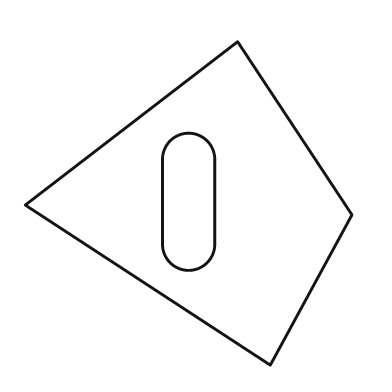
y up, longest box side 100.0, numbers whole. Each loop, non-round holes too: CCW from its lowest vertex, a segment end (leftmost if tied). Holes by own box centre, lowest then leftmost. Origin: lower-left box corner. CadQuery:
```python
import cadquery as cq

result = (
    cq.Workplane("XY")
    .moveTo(75.0, 0.0)
    .lineTo(100.0, 46.0)
    .lineTo(65.0, 99.0)
    .lineTo(0.0, 49.0)
    .close()
    .moveTo(42.0, 37.0)
    .threePointArc((50.0, 29.0), (58.0, 37.0))
    .lineTo(58.0, 63.0)
    .threePointArc((50.0, 71.0), (42.0, 63.0))
    .close()
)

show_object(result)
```